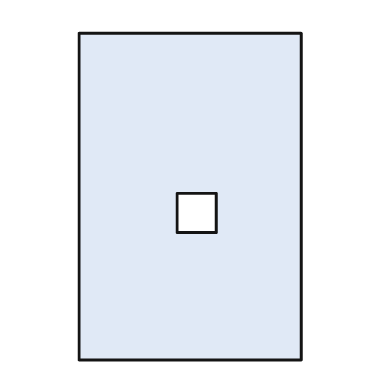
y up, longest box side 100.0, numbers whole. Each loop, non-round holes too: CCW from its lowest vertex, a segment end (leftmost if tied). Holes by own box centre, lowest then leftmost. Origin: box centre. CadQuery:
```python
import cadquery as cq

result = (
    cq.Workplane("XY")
    .moveTo(-34.0, -50.0)
    .lineTo(34.0, -50.0)
    .lineTo(34.0, 50.0)
    .lineTo(-34.0, 50.0)
    .close()
    .moveTo(-4.0, -11.0)
    .lineTo(8.0, -11.0)
    .lineTo(8.0, 1.0)
    .lineTo(-4.0, 1.0)
    .close()
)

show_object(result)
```